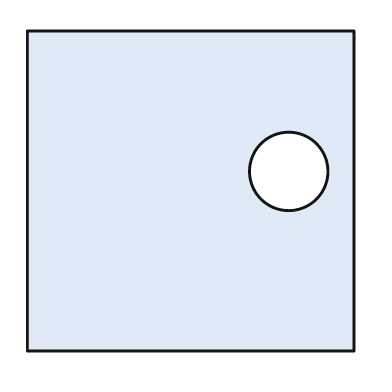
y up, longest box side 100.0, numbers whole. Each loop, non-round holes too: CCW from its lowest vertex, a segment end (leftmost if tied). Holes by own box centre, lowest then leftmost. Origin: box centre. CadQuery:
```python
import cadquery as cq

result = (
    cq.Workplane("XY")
    .moveTo(-50.0, -49.0)
    .lineTo(50.0, -49.0)
    .lineTo(50.0, 49.0)
    .lineTo(-50.0, 49.0)
    .close()
    .moveTo(30.0, 6.0)
    .circle(12.0)
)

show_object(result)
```